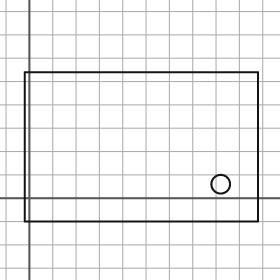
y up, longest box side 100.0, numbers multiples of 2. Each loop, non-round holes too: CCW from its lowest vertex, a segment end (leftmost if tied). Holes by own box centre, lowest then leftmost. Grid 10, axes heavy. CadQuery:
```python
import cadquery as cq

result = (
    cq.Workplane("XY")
    .moveTo(-2.0, -10.0)
    .lineTo(98.0, -10.0)
    .lineTo(98.0, 54.0)
    .lineTo(-2.0, 54.0)
    .close()
    .moveTo(82.0, 6.0)
    .circle(4.0)
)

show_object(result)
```